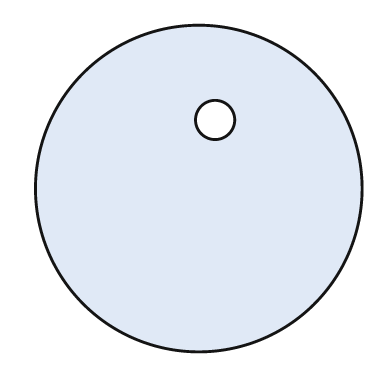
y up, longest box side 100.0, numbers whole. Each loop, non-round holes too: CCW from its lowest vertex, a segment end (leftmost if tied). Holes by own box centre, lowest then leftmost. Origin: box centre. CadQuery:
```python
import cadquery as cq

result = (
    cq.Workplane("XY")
    .moveTo(0.0, 0.0)
    .circle(50.0)
    .moveTo(5.0, 21.0)
    .circle(6.0)
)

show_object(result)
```